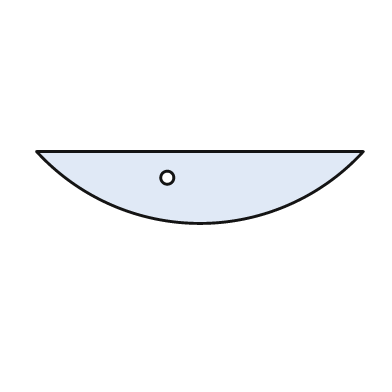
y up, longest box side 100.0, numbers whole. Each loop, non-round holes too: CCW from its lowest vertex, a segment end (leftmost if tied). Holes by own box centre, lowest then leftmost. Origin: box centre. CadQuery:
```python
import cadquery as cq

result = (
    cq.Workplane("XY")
    .moveTo(-50.0, 11.0)
    .threePointArc((0.0, -11.0), (50.0, 11.0))
    .close()
    .moveTo(-10.0, 3.0)
    .circle(2.0)
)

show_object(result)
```